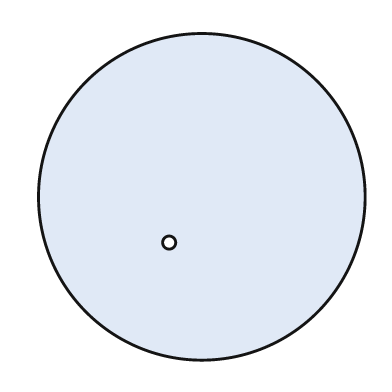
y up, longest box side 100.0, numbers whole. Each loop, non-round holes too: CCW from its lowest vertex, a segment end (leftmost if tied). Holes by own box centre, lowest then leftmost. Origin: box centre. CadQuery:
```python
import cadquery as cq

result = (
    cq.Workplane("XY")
    .moveTo(0.0, 0.0)
    .circle(50.0)
    .moveTo(-10.0, -14.0)
    .circle(2.0)
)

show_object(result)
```